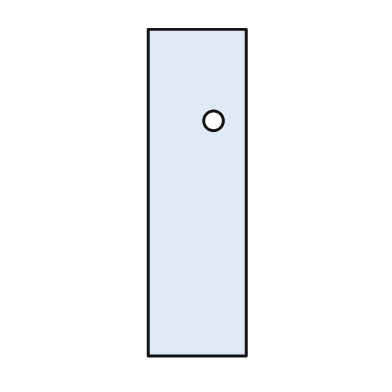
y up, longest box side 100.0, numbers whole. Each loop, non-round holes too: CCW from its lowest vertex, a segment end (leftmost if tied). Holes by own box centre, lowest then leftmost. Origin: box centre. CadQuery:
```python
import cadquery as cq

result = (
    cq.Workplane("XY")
    .moveTo(-15.0, -50.0)
    .lineTo(15.0, -50.0)
    .lineTo(15.0, 50.0)
    .lineTo(-15.0, 50.0)
    .close()
    .moveTo(5.0, 22.0)
    .circle(3.0)
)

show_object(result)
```